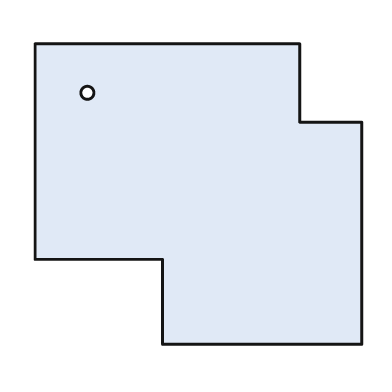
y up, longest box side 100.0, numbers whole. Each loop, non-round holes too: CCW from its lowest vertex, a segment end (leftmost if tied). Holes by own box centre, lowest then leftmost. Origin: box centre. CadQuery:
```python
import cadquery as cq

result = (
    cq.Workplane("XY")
    .moveTo(-11.0, -46.0)
    .lineTo(50.0, -46.0)
    .lineTo(50.0, 22.0)
    .lineTo(31.0, 22.0)
    .lineTo(31.0, 46.0)
    .lineTo(-50.0, 46.0)
    .lineTo(-50.0, -20.0)
    .lineTo(-11.0, -20.0)
    .close()
    .moveTo(-34.0, 31.0)
    .circle(2.0)
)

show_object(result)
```